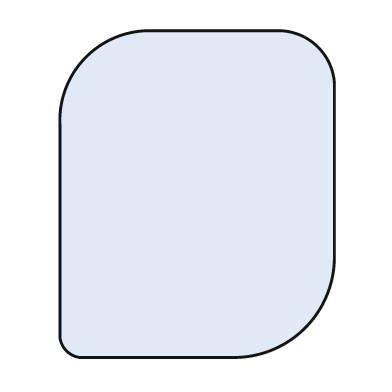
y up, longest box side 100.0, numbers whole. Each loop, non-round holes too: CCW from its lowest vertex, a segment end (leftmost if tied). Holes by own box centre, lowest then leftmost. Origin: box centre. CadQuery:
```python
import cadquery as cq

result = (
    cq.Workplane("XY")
    .moveTo(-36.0, -50.0)
    .lineTo(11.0, -50.0)
    .threePointArc((33.0, -41.0), (42.0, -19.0))
    .lineTo(42.0, 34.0)
    .threePointArc((37.0, 45.0), (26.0, 50.0))
    .lineTo(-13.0, 50.0)
    .threePointArc((-34.0, 42.0), (-42.0, 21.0))
    .lineTo(-42.0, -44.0)
    .threePointArc((-40.0, -48.0), (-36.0, -50.0))
    .close()
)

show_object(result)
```